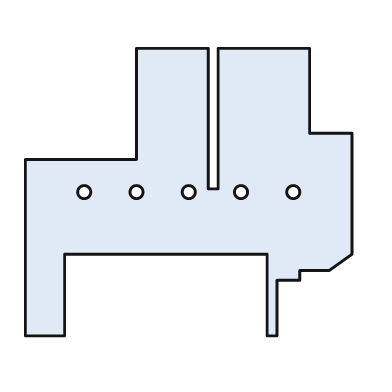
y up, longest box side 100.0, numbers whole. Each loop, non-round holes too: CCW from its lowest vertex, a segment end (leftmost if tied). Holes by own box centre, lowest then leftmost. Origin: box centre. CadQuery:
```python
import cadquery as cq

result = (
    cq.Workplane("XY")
    .moveTo(-50.0, -44.0)
    .lineTo(-38.0, -44.0)
    .lineTo(-38.0, -19.0)
    .lineTo(24.0, -19.0)
    .lineTo(24.0, -44.0)
    .lineTo(27.0, -44.0)
    .lineTo(27.0, -27.0)
    .lineTo(34.0, -27.0)
    .lineTo(34.0, -24.0)
    .lineTo(43.0, -24.0)
    .lineTo(50.0, -19.0)
    .lineTo(50.0, 18.0)
    .lineTo(37.0, 18.0)
    .lineTo(37.0, 44.0)
    .lineTo(9.0, 44.0)
    .lineTo(9.0, 1.0)
    .lineTo(6.0, 1.0)
    .lineTo(6.0, 44.0)
    .lineTo(-16.0, 44.0)
    .lineTo(-16.0, 10.0)
    .lineTo(-50.0, 10.0)
    .close()
    .moveTo(-32.0, 0.0)
    .circle(2.0)
    .moveTo(-16.0, 0.0)
    .circle(2.0)
    .moveTo(0.0, 0.0)
    .circle(2.0)
    .moveTo(16.0, 0.0)
    .circle(2.0)
    .moveTo(32.0, 0.0)
    .circle(2.0)
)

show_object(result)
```